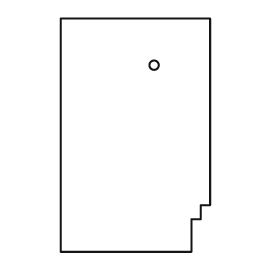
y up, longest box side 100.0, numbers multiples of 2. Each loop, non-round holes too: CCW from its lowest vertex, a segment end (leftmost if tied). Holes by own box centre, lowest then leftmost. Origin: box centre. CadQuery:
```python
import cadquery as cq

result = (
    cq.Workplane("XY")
    .moveTo(-32.0, -50.0)
    .lineTo(24.0, -50.0)
    .lineTo(24.0, -36.0)
    .lineTo(28.0, -36.0)
    .lineTo(28.0, -30.0)
    .lineTo(32.0, -30.0)
    .lineTo(32.0, 50.0)
    .lineTo(-32.0, 50.0)
    .close()
    .moveTo(8.0, 30.0)
    .circle(2.0)
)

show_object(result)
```